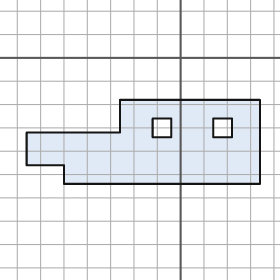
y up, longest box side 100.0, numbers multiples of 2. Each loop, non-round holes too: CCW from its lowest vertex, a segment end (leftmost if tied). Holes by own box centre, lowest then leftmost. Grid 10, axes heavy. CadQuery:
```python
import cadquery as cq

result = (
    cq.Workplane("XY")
    .moveTo(-50.0, -54.0)
    .lineTo(34.0, -54.0)
    .lineTo(34.0, -18.0)
    .lineTo(-26.0, -18.0)
    .lineTo(-26.0, -32.0)
    .lineTo(-66.0, -32.0)
    .lineTo(-66.0, -46.0)
    .lineTo(-50.0, -46.0)
    .close()
    .moveTo(-12.0, -34.0)
    .lineTo(-4.0, -34.0)
    .lineTo(-4.0, -26.0)
    .lineTo(-12.0, -26.0)
    .close()
    .moveTo(14.0, -34.0)
    .lineTo(22.0, -34.0)
    .lineTo(22.0, -26.0)
    .lineTo(14.0, -26.0)
    .close()
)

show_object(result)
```